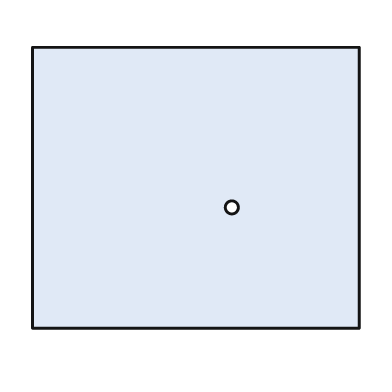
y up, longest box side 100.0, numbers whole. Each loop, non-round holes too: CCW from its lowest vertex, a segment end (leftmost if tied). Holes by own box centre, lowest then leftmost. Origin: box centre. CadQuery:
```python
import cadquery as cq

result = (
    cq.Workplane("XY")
    .moveTo(-50.0, -43.0)
    .lineTo(50.0, -43.0)
    .lineTo(50.0, 43.0)
    .lineTo(-50.0, 43.0)
    .close()
    .moveTo(11.0, -6.0)
    .circle(2.0)
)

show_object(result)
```